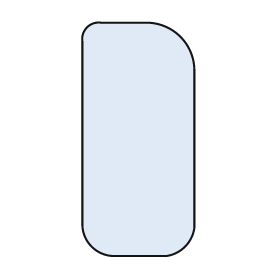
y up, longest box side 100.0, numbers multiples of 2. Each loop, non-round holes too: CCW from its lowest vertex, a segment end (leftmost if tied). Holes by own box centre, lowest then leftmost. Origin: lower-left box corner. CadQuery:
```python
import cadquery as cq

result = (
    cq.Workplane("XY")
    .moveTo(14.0, 0.0)
    .lineTo(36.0, 0.0)
    .threePointArc((44.0, 4.0), (48.0, 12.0))
    .lineTo(48.0, 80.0)
    .threePointArc((42.0, 94.0), (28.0, 100.0))
    .lineTo(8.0, 100.0)
    .threePointArc((2.0, 98.0), (0.0, 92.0))
    .lineTo(0.0, 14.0)
    .threePointArc((4.0, 4.0), (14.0, 0.0))
    .close()
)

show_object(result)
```